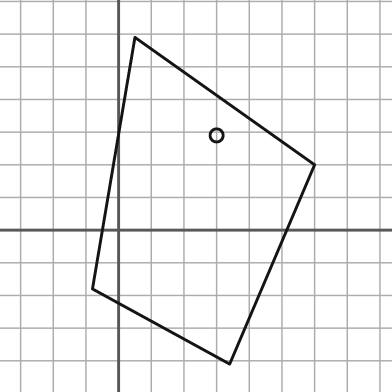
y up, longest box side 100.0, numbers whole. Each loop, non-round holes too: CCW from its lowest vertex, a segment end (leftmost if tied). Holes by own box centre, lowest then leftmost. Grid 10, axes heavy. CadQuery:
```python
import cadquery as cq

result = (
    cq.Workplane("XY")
    .moveTo(34.0, -41.0)
    .lineTo(60.0, 20.0)
    .lineTo(5.0, 59.0)
    .lineTo(-8.0, -18.0)
    .close()
    .moveTo(30.0, 29.0)
    .circle(2.0)
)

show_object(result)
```